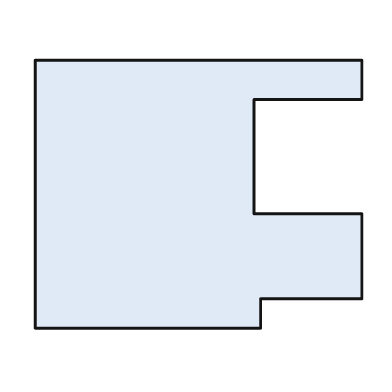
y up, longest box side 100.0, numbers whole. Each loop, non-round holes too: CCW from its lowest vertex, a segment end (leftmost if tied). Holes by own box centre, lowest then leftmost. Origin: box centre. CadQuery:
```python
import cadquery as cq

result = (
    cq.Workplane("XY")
    .moveTo(-50.0, -41.0)
    .lineTo(19.0, -41.0)
    .lineTo(19.0, -32.0)
    .lineTo(50.0, -32.0)
    .lineTo(50.0, -6.0)
    .lineTo(17.0, -6.0)
    .lineTo(17.0, 29.0)
    .lineTo(50.0, 29.0)
    .lineTo(50.0, 41.0)
    .lineTo(-50.0, 41.0)
    .close()
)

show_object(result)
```